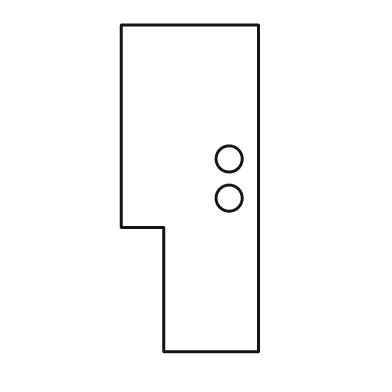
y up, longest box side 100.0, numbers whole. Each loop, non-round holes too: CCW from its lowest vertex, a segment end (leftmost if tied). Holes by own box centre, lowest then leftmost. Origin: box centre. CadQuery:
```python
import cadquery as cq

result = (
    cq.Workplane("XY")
    .moveTo(-8.0, -50.0)
    .lineTo(21.0, -50.0)
    .lineTo(21.0, 50.0)
    .lineTo(-21.0, 50.0)
    .lineTo(-21.0, -12.0)
    .lineTo(-8.0, -12.0)
    .close()
    .moveTo(12.0, -3.0)
    .circle(4.0)
    .moveTo(12.0, 9.0)
    .circle(4.0)
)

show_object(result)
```